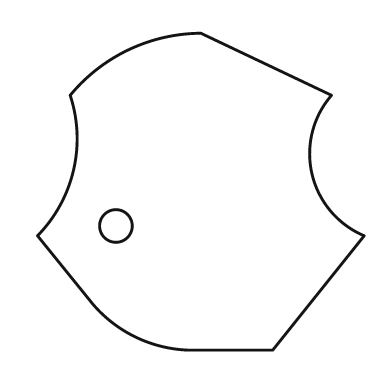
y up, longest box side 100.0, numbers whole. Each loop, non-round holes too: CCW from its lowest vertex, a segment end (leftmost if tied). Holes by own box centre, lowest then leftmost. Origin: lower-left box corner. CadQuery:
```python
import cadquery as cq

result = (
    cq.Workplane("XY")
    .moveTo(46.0, 0.0)
    .lineTo(72.0, 0.0)
    .lineTo(100.0, 35.0)
    .threePointArc((84.0, 54.0), (90.0, 78.0))
    .lineTo(50.0, 97.0)
    .threePointArc((28.0, 92.0), (10.0, 78.0))
    .threePointArc((11.0, 55.0), (0.0, 35.0))
    .lineTo(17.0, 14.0)
    .threePointArc((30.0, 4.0), (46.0, 0.0))
    .close()
    .moveTo(24.0, 38.0)
    .circle(5.0)
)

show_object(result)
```